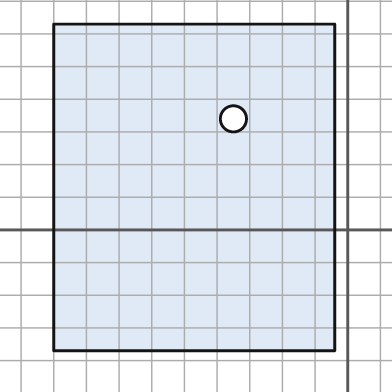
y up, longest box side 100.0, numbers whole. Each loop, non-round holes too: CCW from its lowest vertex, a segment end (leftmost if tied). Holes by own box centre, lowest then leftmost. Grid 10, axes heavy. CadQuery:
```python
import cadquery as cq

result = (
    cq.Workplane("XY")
    .moveTo(-90.0, -37.0)
    .lineTo(-4.0, -37.0)
    .lineTo(-4.0, 63.0)
    .lineTo(-90.0, 63.0)
    .close()
    .moveTo(-35.0, 34.0)
    .circle(4.0)
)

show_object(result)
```